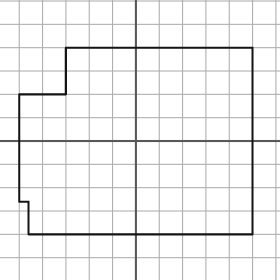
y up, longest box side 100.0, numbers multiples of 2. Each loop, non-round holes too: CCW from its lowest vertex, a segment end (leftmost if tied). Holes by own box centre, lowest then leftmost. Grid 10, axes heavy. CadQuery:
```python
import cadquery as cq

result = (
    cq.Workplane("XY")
    .moveTo(-46.0, -40.0)
    .lineTo(50.0, -40.0)
    .lineTo(50.0, 40.0)
    .lineTo(-30.0, 40.0)
    .lineTo(-30.0, 20.0)
    .lineTo(-50.0, 20.0)
    .lineTo(-50.0, -26.0)
    .lineTo(-46.0, -26.0)
    .close()
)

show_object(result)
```